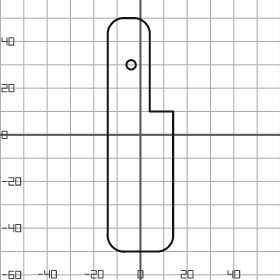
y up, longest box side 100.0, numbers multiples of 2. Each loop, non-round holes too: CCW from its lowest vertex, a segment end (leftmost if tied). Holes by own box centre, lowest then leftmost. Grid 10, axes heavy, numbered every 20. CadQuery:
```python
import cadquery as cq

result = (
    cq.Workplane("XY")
    .moveTo(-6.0, -50.0)
    .lineTo(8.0, -50.0)
    .threePointArc((12.0, -48.0), (14.0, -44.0))
    .lineTo(14.0, 10.0)
    .lineTo(4.0, 10.0)
    .lineTo(4.0, 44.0)
    .threePointArc((2.0, 48.0), (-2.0, 50.0))
    .lineTo(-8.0, 50.0)
    .threePointArc((-12.0, 48.0), (-14.0, 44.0))
    .lineTo(-14.0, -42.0)
    .threePointArc((-12.0, -48.0), (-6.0, -50.0))
    .close()
    .moveTo(-4.0, 30.0)
    .circle(2.0)
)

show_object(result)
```